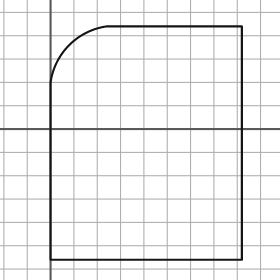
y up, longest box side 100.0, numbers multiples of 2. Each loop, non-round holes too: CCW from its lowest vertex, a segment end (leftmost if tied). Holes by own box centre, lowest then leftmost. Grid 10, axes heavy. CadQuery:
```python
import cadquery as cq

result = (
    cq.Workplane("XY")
    .moveTo(0.0, -56.0)
    .lineTo(82.0, -56.0)
    .lineTo(82.0, 44.0)
    .lineTo(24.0, 44.0)
    .threePointArc((8.0, 36.0), (0.0, 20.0))
    .close()
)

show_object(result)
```